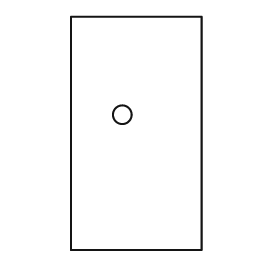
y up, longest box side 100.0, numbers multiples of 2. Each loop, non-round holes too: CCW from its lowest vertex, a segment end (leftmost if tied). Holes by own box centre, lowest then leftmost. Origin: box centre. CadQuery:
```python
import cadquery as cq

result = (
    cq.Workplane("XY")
    .moveTo(-28.0, -50.0)
    .lineTo(28.0, -50.0)
    .lineTo(28.0, 50.0)
    .lineTo(-28.0, 50.0)
    .close()
    .moveTo(-6.0, 8.0)
    .circle(4.0)
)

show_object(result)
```